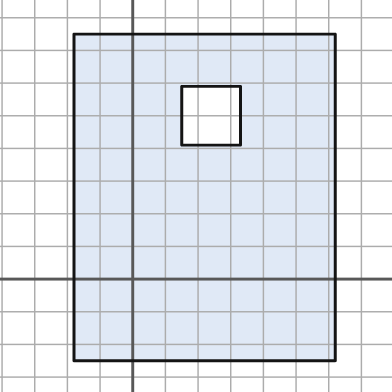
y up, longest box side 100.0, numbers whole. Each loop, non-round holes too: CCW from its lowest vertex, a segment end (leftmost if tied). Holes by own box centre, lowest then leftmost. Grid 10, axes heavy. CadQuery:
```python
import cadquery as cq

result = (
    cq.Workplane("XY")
    .moveTo(-18.0, -25.0)
    .lineTo(62.0, -25.0)
    .lineTo(62.0, 75.0)
    .lineTo(-18.0, 75.0)
    .close()
    .moveTo(15.0, 41.0)
    .lineTo(33.0, 41.0)
    .lineTo(33.0, 59.0)
    .lineTo(15.0, 59.0)
    .close()
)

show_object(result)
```